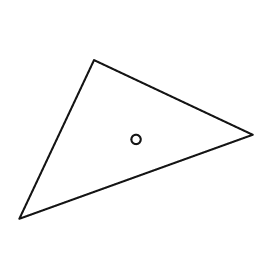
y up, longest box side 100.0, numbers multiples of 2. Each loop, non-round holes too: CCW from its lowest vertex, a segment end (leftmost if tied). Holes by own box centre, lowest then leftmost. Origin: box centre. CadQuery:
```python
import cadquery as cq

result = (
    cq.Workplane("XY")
    .moveTo(-50.0, -34.0)
    .lineTo(50.0, 2.0)
    .lineTo(-18.0, 34.0)
    .close()
    .moveTo(0.0, 0.0)
    .circle(2.0)
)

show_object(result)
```